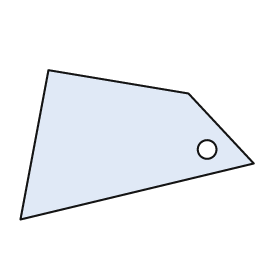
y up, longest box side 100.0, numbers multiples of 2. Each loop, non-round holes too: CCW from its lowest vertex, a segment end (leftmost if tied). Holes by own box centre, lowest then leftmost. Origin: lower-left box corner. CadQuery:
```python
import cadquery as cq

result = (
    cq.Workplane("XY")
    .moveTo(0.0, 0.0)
    .lineTo(100.0, 24.0)
    .lineTo(72.0, 54.0)
    .lineTo(12.0, 64.0)
    .close()
    .moveTo(80.0, 30.0)
    .circle(4.0)
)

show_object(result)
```